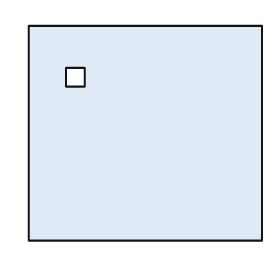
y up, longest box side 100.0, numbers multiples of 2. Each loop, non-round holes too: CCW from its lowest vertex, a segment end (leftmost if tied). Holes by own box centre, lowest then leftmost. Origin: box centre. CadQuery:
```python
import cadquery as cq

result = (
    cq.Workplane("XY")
    .moveTo(-50.0, -46.0)
    .lineTo(50.0, -46.0)
    .lineTo(50.0, 46.0)
    .lineTo(-50.0, 46.0)
    .close()
    .moveTo(-34.0, 20.0)
    .lineTo(-26.0, 20.0)
    .lineTo(-26.0, 28.0)
    .lineTo(-34.0, 28.0)
    .close()
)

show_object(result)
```